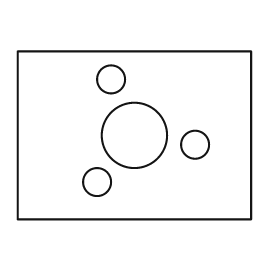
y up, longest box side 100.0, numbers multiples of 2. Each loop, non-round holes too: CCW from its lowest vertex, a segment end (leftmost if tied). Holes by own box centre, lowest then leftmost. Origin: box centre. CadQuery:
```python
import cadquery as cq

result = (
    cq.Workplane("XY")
    .moveTo(-50.0, -36.0)
    .lineTo(50.0, -36.0)
    .lineTo(50.0, 36.0)
    .lineTo(-50.0, 36.0)
    .close()
    .moveTo(-16.0, -20.0)
    .circle(6.0)
    .moveTo(26.0, -4.0)
    .circle(6.0)
    .moveTo(0.0, 0.0)
    .circle(14.0)
    .moveTo(-10.0, 24.0)
    .circle(6.0)
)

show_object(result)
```